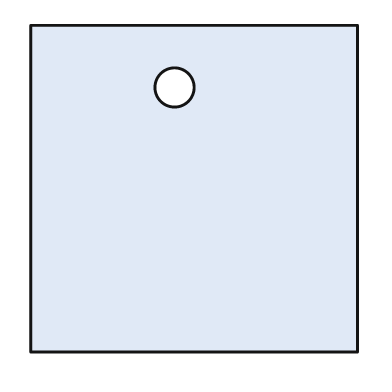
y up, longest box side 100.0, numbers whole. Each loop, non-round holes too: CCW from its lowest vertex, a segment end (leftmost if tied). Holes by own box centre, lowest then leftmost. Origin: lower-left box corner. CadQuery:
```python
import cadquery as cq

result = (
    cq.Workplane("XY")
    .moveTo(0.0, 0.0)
    .lineTo(100.0, 0.0)
    .lineTo(100.0, 100.0)
    .lineTo(0.0, 100.0)
    .close()
    .moveTo(44.0, 81.0)
    .circle(6.0)
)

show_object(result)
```